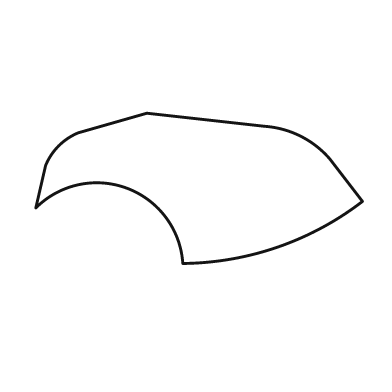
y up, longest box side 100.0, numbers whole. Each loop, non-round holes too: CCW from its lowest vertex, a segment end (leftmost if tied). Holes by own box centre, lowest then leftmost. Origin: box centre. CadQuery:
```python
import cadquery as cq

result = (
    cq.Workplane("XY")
    .moveTo(-5.0, -23.0)
    .threePointArc((24.0, -18.0), (50.0, -4.0))
    .lineTo(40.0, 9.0)
    .threePointArc((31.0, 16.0), (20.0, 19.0))
    .lineTo(-16.0, 23.0)
    .lineTo(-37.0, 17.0)
    .threePointArc((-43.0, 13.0), (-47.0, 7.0))
    .lineTo(-50.0, -6.0)
    .threePointArc((-22.0, 0.0), (-5.0, -23.0))
    .close()
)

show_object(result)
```